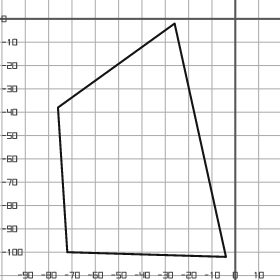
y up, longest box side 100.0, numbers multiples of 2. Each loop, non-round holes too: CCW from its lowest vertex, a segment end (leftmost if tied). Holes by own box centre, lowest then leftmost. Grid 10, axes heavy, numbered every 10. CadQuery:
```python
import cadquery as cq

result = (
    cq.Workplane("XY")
    .moveTo(-4.0, -102.0)
    .lineTo(-26.0, -2.0)
    .lineTo(-76.0, -38.0)
    .lineTo(-72.0, -100.0)
    .close()
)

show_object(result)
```